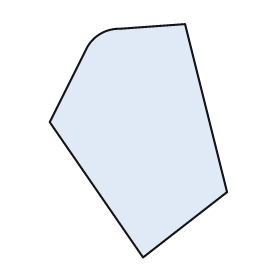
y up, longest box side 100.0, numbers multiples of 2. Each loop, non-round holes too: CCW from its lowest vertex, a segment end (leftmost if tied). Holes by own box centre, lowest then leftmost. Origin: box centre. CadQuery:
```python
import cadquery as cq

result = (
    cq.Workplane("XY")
    .moveTo(2.0, -50.0)
    .lineTo(38.0, -22.0)
    .lineTo(20.0, 50.0)
    .lineTo(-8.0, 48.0)
    .threePointArc((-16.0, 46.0), (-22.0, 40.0))
    .lineTo(-38.0, 8.0)
    .close()
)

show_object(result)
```